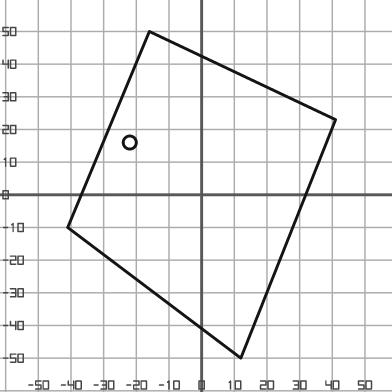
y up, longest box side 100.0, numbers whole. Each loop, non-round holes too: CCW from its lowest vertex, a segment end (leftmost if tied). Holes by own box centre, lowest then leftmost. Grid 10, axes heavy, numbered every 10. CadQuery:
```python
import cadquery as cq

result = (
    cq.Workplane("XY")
    .moveTo(12.0, -50.0)
    .lineTo(41.0, 23.0)
    .lineTo(-16.0, 50.0)
    .lineTo(-41.0, -10.0)
    .close()
    .moveTo(-22.0, 16.0)
    .circle(2.0)
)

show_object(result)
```